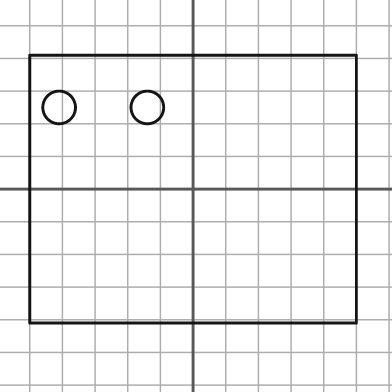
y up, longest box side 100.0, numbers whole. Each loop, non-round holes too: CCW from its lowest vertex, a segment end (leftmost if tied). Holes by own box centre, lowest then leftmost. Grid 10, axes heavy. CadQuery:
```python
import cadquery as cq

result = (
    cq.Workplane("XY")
    .moveTo(-50.0, -41.0)
    .lineTo(50.0, -41.0)
    .lineTo(50.0, 41.0)
    .lineTo(-50.0, 41.0)
    .close()
    .moveTo(-41.0, 25.0)
    .circle(5.0)
    .moveTo(-14.0, 25.0)
    .circle(5.0)
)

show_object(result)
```